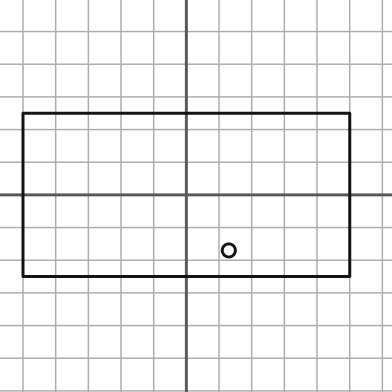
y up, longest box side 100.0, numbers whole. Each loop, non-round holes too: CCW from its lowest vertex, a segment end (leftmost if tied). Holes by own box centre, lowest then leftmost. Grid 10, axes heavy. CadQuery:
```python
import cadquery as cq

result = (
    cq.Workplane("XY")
    .moveTo(-50.0, -25.0)
    .lineTo(50.0, -25.0)
    .lineTo(50.0, 25.0)
    .lineTo(-50.0, 25.0)
    .close()
    .moveTo(13.0, -17.0)
    .circle(2.0)
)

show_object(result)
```